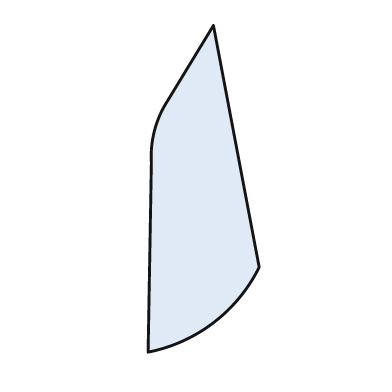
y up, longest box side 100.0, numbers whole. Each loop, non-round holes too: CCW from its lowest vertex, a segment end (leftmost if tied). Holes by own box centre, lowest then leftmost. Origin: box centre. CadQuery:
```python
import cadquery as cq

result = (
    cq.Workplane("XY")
    .moveTo(-17.0, -50.0)
    .threePointArc((3.0, -41.0), (17.0, -24.0))
    .lineTo(3.0, 50.0)
    .lineTo(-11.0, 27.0)
    .threePointArc((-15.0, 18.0), (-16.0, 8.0))
    .close()
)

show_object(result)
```